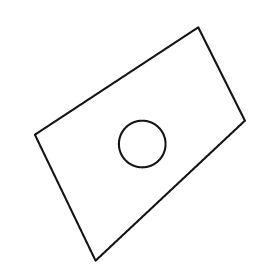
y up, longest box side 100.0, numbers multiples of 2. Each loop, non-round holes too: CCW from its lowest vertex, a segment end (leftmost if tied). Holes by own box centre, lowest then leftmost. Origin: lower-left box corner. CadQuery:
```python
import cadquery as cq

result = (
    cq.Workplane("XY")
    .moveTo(26.0, 0.0)
    .lineTo(90.0, 60.0)
    .lineTo(70.0, 100.0)
    .lineTo(0.0, 54.0)
    .close()
    .moveTo(46.0, 50.0)
    .circle(10.0)
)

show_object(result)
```